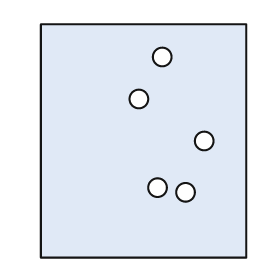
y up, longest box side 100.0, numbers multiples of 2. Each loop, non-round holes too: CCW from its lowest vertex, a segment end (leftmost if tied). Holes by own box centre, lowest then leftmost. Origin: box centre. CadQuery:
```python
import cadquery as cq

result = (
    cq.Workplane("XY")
    .moveTo(-44.0, -50.0)
    .lineTo(44.0, -50.0)
    .lineTo(44.0, 50.0)
    .lineTo(-44.0, 50.0)
    .close()
    .moveTo(18.0, -22.0)
    .circle(4.0)
    .moveTo(6.0, -20.0)
    .circle(4.0)
    .moveTo(26.0, 0.0)
    .circle(4.0)
    .moveTo(-2.0, 18.0)
    .circle(4.0)
    .moveTo(8.0, 36.0)
    .circle(4.0)
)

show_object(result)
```